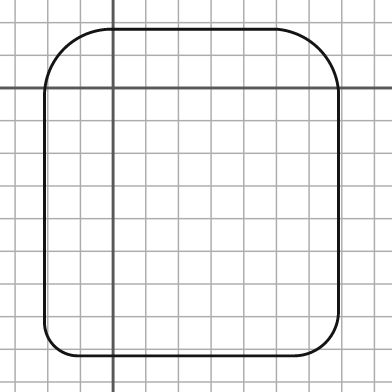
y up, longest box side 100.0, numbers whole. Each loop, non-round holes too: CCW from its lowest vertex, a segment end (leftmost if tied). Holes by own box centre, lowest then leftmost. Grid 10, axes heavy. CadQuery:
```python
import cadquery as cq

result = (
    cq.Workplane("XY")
    .moveTo(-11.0, -82.0)
    .lineTo(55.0, -82.0)
    .threePointArc((65.0, -78.0), (69.0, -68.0))
    .lineTo(69.0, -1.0)
    .threePointArc((63.0, 12.0), (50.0, 18.0))
    .lineTo(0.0, 18.0)
    .threePointArc((-15.0, 12.0), (-21.0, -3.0))
    .lineTo(-21.0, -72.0)
    .threePointArc((-18.0, -79.0), (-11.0, -82.0))
    .close()
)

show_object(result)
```